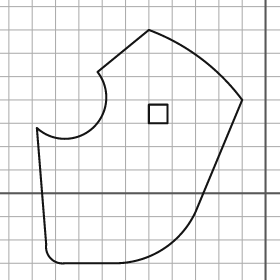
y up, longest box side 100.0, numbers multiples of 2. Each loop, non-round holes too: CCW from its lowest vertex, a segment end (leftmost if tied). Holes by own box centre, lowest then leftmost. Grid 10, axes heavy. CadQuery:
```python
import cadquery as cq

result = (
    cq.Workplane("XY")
    .moveTo(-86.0, -30.0)
    .lineTo(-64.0, -30.0)
    .threePointArc((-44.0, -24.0), (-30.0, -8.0))
    .lineTo(-10.0, 40.0)
    .threePointArc((-28.0, 58.0), (-50.0, 70.0))
    .lineTo(-72.0, 52.0)
    .threePointArc((-74.0, 28.0), (-98.0, 28.0))
    .lineTo(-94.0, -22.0)
    .threePointArc((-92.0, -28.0), (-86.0, -30.0))
    .close()
    .moveTo(-50.0, 30.0)
    .lineTo(-42.0, 30.0)
    .lineTo(-42.0, 38.0)
    .lineTo(-50.0, 38.0)
    .close()
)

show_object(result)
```